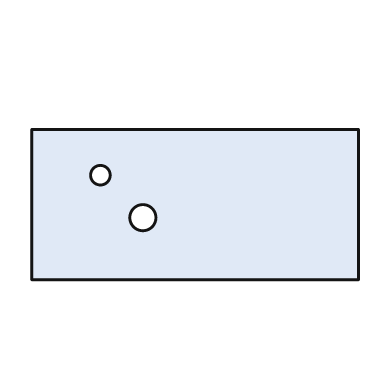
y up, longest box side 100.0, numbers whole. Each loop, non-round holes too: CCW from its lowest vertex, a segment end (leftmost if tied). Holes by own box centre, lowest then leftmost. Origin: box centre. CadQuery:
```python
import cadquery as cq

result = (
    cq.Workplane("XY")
    .moveTo(-50.0, -23.0)
    .lineTo(50.0, -23.0)
    .lineTo(50.0, 23.0)
    .lineTo(-50.0, 23.0)
    .close()
    .moveTo(-16.0, -4.0)
    .circle(4.0)
    .moveTo(-29.0, 9.0)
    .circle(3.0)
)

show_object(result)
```